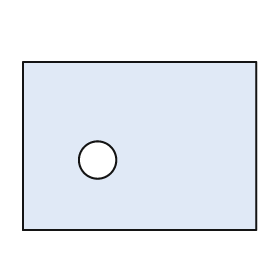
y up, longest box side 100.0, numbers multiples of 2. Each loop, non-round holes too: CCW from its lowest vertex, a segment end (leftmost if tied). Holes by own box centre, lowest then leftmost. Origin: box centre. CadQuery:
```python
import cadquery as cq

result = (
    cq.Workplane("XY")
    .moveTo(-50.0, -36.0)
    .lineTo(50.0, -36.0)
    .lineTo(50.0, 36.0)
    .lineTo(-50.0, 36.0)
    .close()
    .moveTo(-18.0, -6.0)
    .circle(8.0)
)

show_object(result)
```